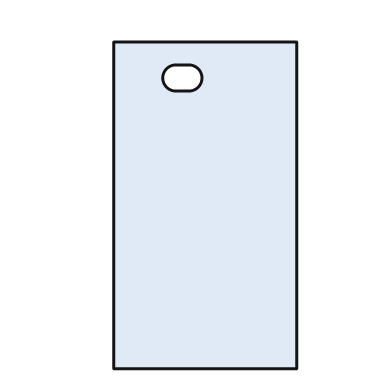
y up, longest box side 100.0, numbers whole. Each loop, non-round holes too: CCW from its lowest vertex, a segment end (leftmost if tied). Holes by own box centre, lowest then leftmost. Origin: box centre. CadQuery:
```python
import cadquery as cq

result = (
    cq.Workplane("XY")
    .moveTo(-28.0, -50.0)
    .lineTo(28.0, -50.0)
    .lineTo(28.0, 50.0)
    .lineTo(-28.0, 50.0)
    .close()
    .moveTo(-9.0, 35.0)
    .lineTo(-5.0, 35.0)
    .threePointArc((-1.0, 39.0), (-5.0, 43.0))
    .lineTo(-9.0, 43.0)
    .threePointArc((-13.0, 39.0), (-9.0, 35.0))
    .close()
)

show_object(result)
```